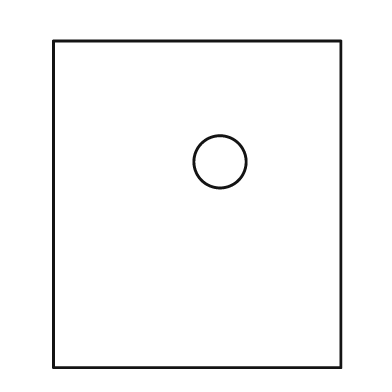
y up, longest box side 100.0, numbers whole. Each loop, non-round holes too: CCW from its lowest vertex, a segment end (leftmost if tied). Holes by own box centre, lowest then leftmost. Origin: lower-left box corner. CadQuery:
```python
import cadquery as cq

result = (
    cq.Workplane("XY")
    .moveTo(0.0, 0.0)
    .lineTo(88.0, 0.0)
    .lineTo(88.0, 100.0)
    .lineTo(0.0, 100.0)
    .close()
    .moveTo(51.0, 63.0)
    .circle(8.0)
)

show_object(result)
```